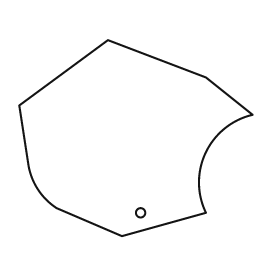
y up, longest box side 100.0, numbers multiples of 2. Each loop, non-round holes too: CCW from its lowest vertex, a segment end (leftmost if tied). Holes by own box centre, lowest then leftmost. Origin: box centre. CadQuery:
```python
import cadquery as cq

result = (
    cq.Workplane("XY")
    .moveTo(-6.0, -42.0)
    .lineTo(30.0, -32.0)
    .threePointArc((30.0, -6.0), (50.0, 10.0))
    .lineTo(30.0, 26.0)
    .lineTo(-12.0, 42.0)
    .lineTo(-50.0, 14.0)
    .lineTo(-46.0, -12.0)
    .threePointArc((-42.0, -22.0), (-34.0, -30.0))
    .close()
    .moveTo(2.0, -32.0)
    .circle(2.0)
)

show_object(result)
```